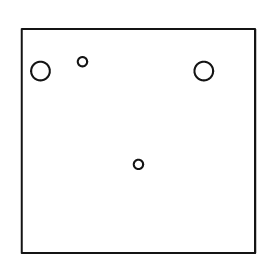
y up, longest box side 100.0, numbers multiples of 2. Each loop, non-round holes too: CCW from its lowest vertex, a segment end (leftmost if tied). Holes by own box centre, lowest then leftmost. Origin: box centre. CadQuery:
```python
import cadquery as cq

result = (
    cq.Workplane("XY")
    .moveTo(-50.0, -48.0)
    .lineTo(50.0, -48.0)
    .lineTo(50.0, 48.0)
    .lineTo(-50.0, 48.0)
    .close()
    .moveTo(0.0, -10.0)
    .circle(2.0)
    .moveTo(-42.0, 30.0)
    .circle(4.0)
    .moveTo(28.0, 30.0)
    .circle(4.0)
    .moveTo(-24.0, 34.0)
    .circle(2.0)
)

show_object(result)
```